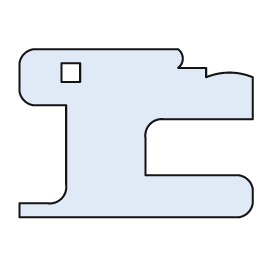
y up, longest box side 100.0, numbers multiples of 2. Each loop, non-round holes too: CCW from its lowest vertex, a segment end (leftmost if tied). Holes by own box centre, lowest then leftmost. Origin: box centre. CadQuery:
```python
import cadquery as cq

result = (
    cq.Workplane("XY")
    .moveTo(-50.0, -36.0)
    .lineTo(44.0, -36.0)
    .threePointArc((48.0, -34.0), (50.0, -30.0))
    .lineTo(50.0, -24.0)
    .threePointArc((48.0, -20.0), (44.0, -18.0))
    .lineTo(4.0, -18.0)
    .lineTo(4.0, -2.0)
    .threePointArc((6.0, 4.0), (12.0, 6.0))
    .lineTo(50.0, 6.0)
    .lineTo(50.0, 24.0)
    .threePointArc((40.0, 26.0), (30.0, 24.0))
    .lineTo(30.0, 28.0)
    .lineTo(18.0, 28.0)
    .threePointArc((20.0, 32.0), (18.0, 36.0))
    .lineTo(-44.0, 36.0)
    .threePointArc((-48.0, 34.0), (-50.0, 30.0))
    .lineTo(-50.0, 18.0)
    .threePointArc((-48.0, 14.0), (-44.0, 12.0))
    .lineTo(-30.0, 12.0)
    .lineTo(-30.0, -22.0)
    .threePointArc((-32.0, -28.0), (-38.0, -30.0))
    .lineTo(-50.0, -30.0)
    .close()
    .moveTo(-32.0, 22.0)
    .lineTo(-24.0, 22.0)
    .lineTo(-24.0, 30.0)
    .lineTo(-32.0, 30.0)
    .close()
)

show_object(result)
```